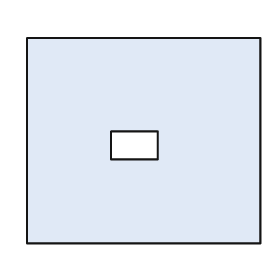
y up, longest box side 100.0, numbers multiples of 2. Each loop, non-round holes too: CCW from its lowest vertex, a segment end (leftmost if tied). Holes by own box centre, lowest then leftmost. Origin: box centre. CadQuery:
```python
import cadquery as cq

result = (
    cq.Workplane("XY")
    .moveTo(-50.0, -44.0)
    .lineTo(50.0, -44.0)
    .lineTo(50.0, 44.0)
    .lineTo(-50.0, 44.0)
    .close()
    .moveTo(-14.0, -8.0)
    .lineTo(6.0, -8.0)
    .lineTo(6.0, 4.0)
    .lineTo(-14.0, 4.0)
    .close()
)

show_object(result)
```